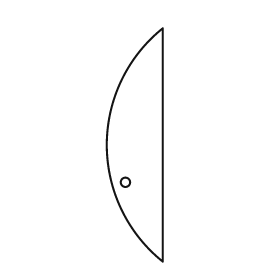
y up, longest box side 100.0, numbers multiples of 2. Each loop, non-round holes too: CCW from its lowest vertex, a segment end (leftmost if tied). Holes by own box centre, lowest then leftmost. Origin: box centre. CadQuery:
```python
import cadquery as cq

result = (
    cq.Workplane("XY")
    .moveTo(12.0, -50.0)
    .lineTo(12.0, 50.0)
    .threePointArc((-12.0, 0.0), (12.0, -50.0))
    .close()
    .moveTo(-4.0, -16.0)
    .circle(2.0)
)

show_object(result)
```